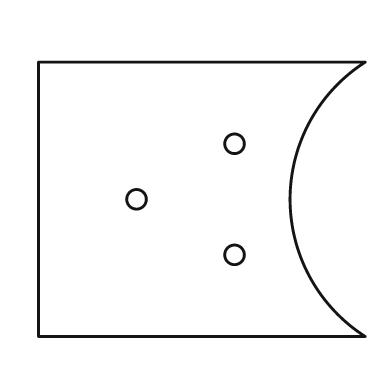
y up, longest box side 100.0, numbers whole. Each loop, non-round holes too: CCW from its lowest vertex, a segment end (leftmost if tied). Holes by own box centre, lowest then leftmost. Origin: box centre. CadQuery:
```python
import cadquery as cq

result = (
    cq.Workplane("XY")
    .moveTo(-50.0, -42.0)
    .lineTo(50.0, -42.0)
    .threePointArc((27.0, 0.0), (50.0, 42.0))
    .lineTo(-50.0, 42.0)
    .close()
    .moveTo(10.0, -17.0)
    .circle(3.0)
    .moveTo(-20.0, 0.0)
    .circle(3.0)
    .moveTo(10.0, 17.0)
    .circle(3.0)
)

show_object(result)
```